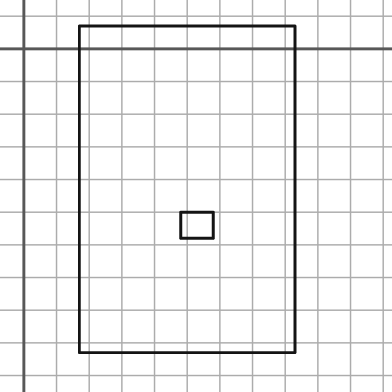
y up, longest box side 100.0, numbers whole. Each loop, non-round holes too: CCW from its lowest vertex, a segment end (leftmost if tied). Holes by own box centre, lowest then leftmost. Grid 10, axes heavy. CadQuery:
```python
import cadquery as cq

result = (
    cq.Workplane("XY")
    .moveTo(17.0, -93.0)
    .lineTo(83.0, -93.0)
    .lineTo(83.0, 7.0)
    .lineTo(17.0, 7.0)
    .close()
    .moveTo(48.0, -58.0)
    .lineTo(58.0, -58.0)
    .lineTo(58.0, -50.0)
    .lineTo(48.0, -50.0)
    .close()
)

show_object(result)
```